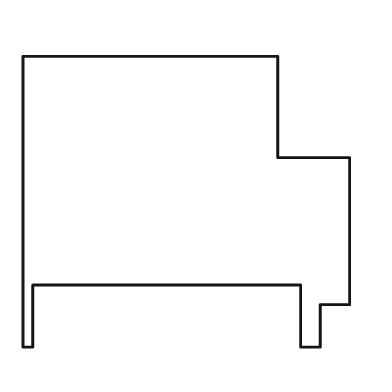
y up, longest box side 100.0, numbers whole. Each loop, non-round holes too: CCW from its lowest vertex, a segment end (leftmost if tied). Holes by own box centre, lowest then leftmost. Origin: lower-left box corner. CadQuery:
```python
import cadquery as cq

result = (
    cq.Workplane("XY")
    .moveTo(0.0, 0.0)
    .lineTo(3.0, 0.0)
    .lineTo(3.0, 19.0)
    .lineTo(85.0, 19.0)
    .lineTo(85.0, 0.0)
    .lineTo(91.0, 0.0)
    .lineTo(91.0, 13.0)
    .lineTo(100.0, 13.0)
    .lineTo(100.0, 58.0)
    .lineTo(78.0, 58.0)
    .lineTo(78.0, 89.0)
    .lineTo(0.0, 89.0)
    .close()
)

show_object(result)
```